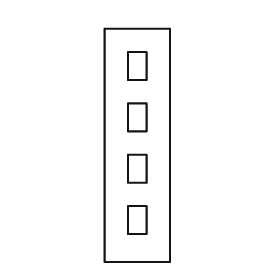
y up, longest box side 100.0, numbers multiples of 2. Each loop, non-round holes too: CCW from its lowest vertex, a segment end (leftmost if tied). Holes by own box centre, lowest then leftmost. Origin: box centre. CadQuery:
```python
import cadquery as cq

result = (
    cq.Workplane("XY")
    .moveTo(-14.0, -50.0)
    .lineTo(14.0, -50.0)
    .lineTo(14.0, 50.0)
    .lineTo(-14.0, 50.0)
    .close()
    .moveTo(-4.0, -38.0)
    .lineTo(4.0, -38.0)
    .lineTo(4.0, -26.0)
    .lineTo(-4.0, -26.0)
    .close()
    .moveTo(-4.0, -16.0)
    .lineTo(4.0, -16.0)
    .lineTo(4.0, -4.0)
    .lineTo(-4.0, -4.0)
    .close()
    .moveTo(-4.0, 6.0)
    .lineTo(4.0, 6.0)
    .lineTo(4.0, 18.0)
    .lineTo(-4.0, 18.0)
    .close()
    .moveTo(-4.0, 28.0)
    .lineTo(4.0, 28.0)
    .lineTo(4.0, 40.0)
    .lineTo(-4.0, 40.0)
    .close()
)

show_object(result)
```